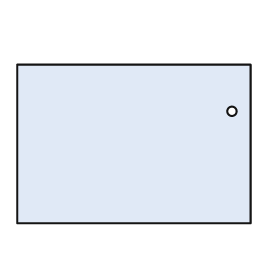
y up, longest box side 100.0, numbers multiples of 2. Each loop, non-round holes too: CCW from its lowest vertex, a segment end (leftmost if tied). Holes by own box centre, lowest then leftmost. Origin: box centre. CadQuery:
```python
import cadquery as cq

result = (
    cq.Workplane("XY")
    .moveTo(-50.0, -34.0)
    .lineTo(50.0, -34.0)
    .lineTo(50.0, 34.0)
    .lineTo(-50.0, 34.0)
    .close()
    .moveTo(42.0, 14.0)
    .circle(2.0)
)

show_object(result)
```